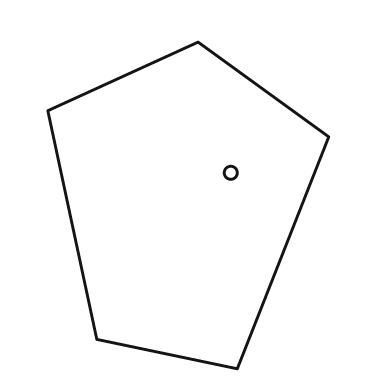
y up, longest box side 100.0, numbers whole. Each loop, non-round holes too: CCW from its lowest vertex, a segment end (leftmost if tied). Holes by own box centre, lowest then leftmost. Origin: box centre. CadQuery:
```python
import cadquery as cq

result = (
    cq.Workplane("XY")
    .moveTo(15.0, -50.0)
    .lineTo(43.0, 21.0)
    .lineTo(3.0, 50.0)
    .lineTo(-43.0, 29.0)
    .lineTo(-28.0, -41.0)
    .close()
    .moveTo(13.0, 10.0)
    .circle(2.0)
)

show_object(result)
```